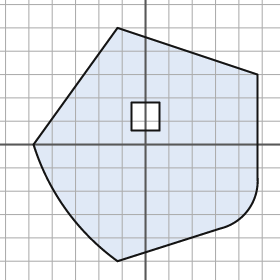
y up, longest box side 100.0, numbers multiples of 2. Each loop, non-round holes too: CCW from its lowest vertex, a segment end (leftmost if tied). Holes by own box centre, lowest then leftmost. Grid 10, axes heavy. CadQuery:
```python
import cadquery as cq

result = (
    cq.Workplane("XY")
    .moveTo(-12.0, -50.0)
    .lineTo(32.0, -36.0)
    .threePointArc((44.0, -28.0), (48.0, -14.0))
    .lineTo(48.0, 30.0)
    .lineTo(-12.0, 50.0)
    .lineTo(-48.0, 0.0)
    .threePointArc((-34.0, -28.0), (-12.0, -50.0))
    .close()
    .moveTo(-6.0, 6.0)
    .lineTo(6.0, 6.0)
    .lineTo(6.0, 18.0)
    .lineTo(-6.0, 18.0)
    .close()
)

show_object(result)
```